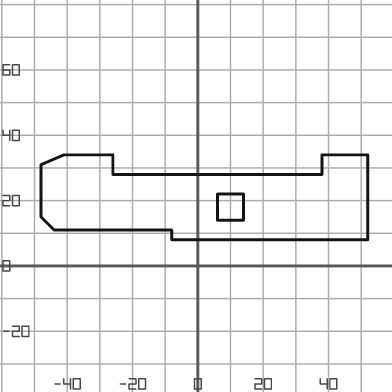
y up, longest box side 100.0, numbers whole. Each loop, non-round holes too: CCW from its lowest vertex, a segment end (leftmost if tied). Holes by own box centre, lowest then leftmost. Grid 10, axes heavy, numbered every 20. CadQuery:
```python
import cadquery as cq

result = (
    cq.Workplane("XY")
    .moveTo(-8.0, 8.0)
    .lineTo(52.0, 8.0)
    .lineTo(52.0, 34.0)
    .lineTo(38.0, 34.0)
    .lineTo(38.0, 28.0)
    .lineTo(-26.0, 28.0)
    .lineTo(-26.0, 34.0)
    .lineTo(-41.0, 34.0)
    .lineTo(-48.0, 31.0)
    .lineTo(-48.0, 15.0)
    .lineTo(-44.0, 11.0)
    .lineTo(-8.0, 11.0)
    .close()
    .moveTo(6.0, 14.0)
    .lineTo(14.0, 14.0)
    .lineTo(14.0, 22.0)
    .lineTo(6.0, 22.0)
    .close()
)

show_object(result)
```